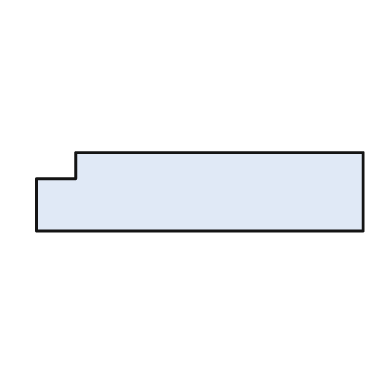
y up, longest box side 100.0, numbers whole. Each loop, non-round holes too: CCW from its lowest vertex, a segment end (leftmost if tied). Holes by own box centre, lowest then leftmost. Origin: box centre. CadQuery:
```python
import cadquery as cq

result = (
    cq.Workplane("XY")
    .moveTo(-50.0, -12.0)
    .lineTo(50.0, -12.0)
    .lineTo(50.0, 12.0)
    .lineTo(-38.0, 12.0)
    .lineTo(-38.0, 4.0)
    .lineTo(-50.0, 4.0)
    .close()
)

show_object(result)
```